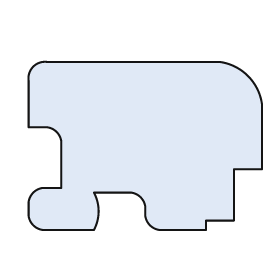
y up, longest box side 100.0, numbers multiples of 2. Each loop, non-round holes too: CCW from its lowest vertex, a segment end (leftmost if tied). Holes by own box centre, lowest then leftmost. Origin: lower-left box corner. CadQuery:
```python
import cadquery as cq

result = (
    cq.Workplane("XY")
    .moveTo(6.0, 0.0)
    .lineTo(28.0, 0.0)
    .threePointArc((30.0, 8.0), (28.0, 16.0))
    .lineTo(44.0, 16.0)
    .threePointArc((48.0, 14.0), (50.0, 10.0))
    .lineTo(50.0, 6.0)
    .threePointArc((52.0, 2.0), (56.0, 0.0))
    .lineTo(76.0, 0.0)
    .lineTo(76.0, 4.0)
    .lineTo(88.0, 4.0)
    .lineTo(88.0, 26.0)
    .lineTo(100.0, 26.0)
    .lineTo(100.0, 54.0)
    .threePointArc((94.0, 66.0), (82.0, 72.0))
    .lineTo(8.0, 72.0)
    .threePointArc((2.0, 70.0), (0.0, 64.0))
    .lineTo(0.0, 44.0)
    .lineTo(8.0, 44.0)
    .threePointArc((12.0, 42.0), (14.0, 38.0))
    .lineTo(14.0, 18.0)
    .lineTo(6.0, 18.0)
    .threePointArc((2.0, 16.0), (0.0, 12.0))
    .lineTo(0.0, 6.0)
    .threePointArc((2.0, 2.0), (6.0, 0.0))
    .close()
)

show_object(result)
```